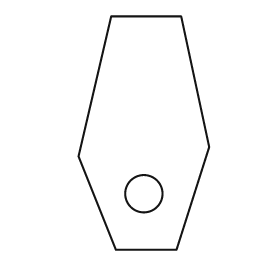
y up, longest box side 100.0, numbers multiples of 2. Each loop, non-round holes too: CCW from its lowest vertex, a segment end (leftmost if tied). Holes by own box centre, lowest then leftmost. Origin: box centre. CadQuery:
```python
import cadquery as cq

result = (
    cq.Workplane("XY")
    .moveTo(-12.0, -50.0)
    .lineTo(14.0, -50.0)
    .lineTo(28.0, -6.0)
    .lineTo(16.0, 50.0)
    .lineTo(-14.0, 50.0)
    .lineTo(-28.0, -10.0)
    .close()
    .moveTo(0.0, -26.0)
    .circle(8.0)
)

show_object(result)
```